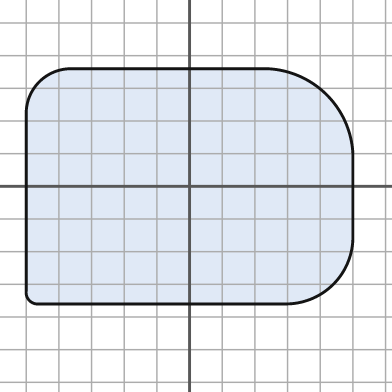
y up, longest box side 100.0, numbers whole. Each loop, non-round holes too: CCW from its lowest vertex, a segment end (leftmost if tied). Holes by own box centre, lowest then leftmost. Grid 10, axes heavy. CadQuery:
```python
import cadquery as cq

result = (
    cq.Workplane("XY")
    .moveTo(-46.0, -36.0)
    .lineTo(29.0, -36.0)
    .threePointArc((44.0, -30.0), (50.0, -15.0))
    .lineTo(50.0, 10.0)
    .threePointArc((42.0, 28.0), (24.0, 36.0))
    .lineTo(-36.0, 36.0)
    .threePointArc((-46.0, 32.0), (-50.0, 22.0))
    .lineTo(-50.0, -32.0)
    .threePointArc((-49.0, -35.0), (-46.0, -36.0))
    .close()
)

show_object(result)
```